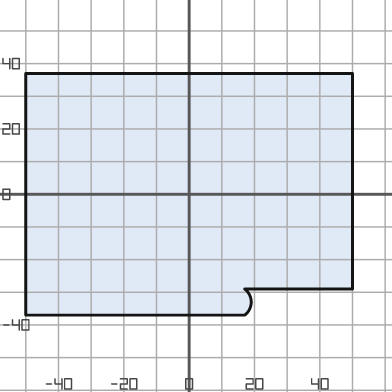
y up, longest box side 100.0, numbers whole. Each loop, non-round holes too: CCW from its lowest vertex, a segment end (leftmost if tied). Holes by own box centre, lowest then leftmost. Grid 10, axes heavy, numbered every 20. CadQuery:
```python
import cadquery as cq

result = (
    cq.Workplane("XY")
    .moveTo(-50.0, -37.0)
    .lineTo(17.0, -37.0)
    .threePointArc((19.0, -33.0), (17.0, -29.0))
    .lineTo(50.0, -29.0)
    .lineTo(50.0, 37.0)
    .lineTo(-50.0, 37.0)
    .close()
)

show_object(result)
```